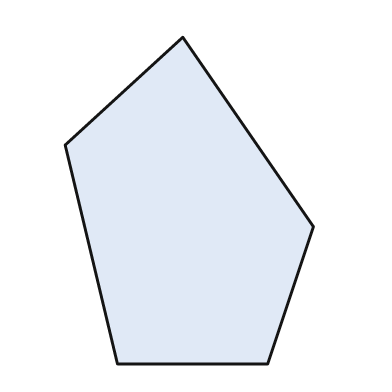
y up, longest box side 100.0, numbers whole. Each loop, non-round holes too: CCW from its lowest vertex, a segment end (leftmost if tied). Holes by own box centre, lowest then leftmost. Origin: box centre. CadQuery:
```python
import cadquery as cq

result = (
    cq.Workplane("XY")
    .moveTo(-22.0, -50.0)
    .lineTo(24.0, -50.0)
    .lineTo(38.0, -8.0)
    .lineTo(-2.0, 50.0)
    .lineTo(-38.0, 17.0)
    .close()
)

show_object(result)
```